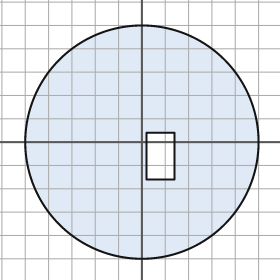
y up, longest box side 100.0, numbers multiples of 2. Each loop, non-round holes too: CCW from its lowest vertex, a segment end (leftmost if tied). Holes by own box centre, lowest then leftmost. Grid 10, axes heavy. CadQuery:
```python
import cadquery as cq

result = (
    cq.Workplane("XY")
    .moveTo(0.0, 0.0)
    .circle(50.0)
    .moveTo(2.0, -16.0)
    .lineTo(14.0, -16.0)
    .lineTo(14.0, 4.0)
    .lineTo(2.0, 4.0)
    .close()
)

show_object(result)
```